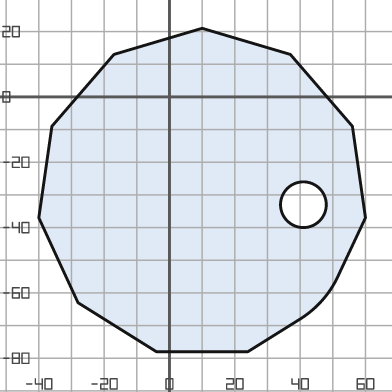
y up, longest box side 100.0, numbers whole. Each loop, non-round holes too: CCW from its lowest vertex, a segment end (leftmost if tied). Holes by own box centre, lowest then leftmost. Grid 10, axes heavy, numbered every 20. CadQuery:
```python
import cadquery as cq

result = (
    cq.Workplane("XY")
    .moveTo(-4.0, -78.0)
    .lineTo(24.0, -78.0)
    .lineTo(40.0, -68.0)
    .threePointArc((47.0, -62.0), (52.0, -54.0))
    .lineTo(60.0, -37.0)
    .lineTo(56.0, -9.0)
    .lineTo(37.0, 13.0)
    .lineTo(10.0, 21.0)
    .lineTo(-17.0, 13.0)
    .lineTo(-36.0, -9.0)
    .lineTo(-40.0, -37.0)
    .lineTo(-28.0, -63.0)
    .close()
    .moveTo(41.0, -33.0)
    .circle(7.0)
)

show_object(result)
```